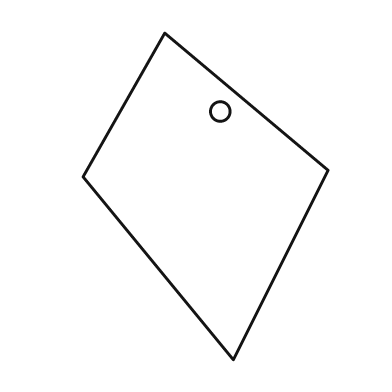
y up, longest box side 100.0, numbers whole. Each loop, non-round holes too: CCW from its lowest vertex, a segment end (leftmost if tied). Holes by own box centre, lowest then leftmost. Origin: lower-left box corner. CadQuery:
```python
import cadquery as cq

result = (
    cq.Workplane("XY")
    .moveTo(46.0, 0.0)
    .lineTo(75.0, 58.0)
    .lineTo(25.0, 100.0)
    .lineTo(0.0, 56.0)
    .close()
    .moveTo(42.0, 76.0)
    .circle(3.0)
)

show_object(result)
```